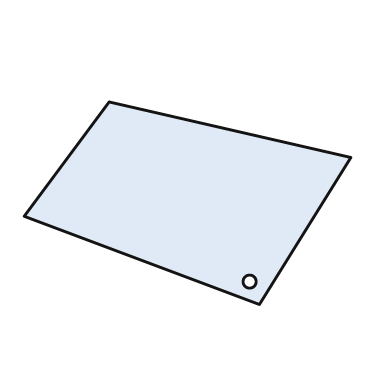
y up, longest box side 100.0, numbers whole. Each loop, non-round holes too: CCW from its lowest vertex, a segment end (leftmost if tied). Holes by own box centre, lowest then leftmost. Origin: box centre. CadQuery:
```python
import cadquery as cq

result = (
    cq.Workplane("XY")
    .moveTo(22.0, -31.0)
    .lineTo(50.0, 14.0)
    .lineTo(-24.0, 31.0)
    .lineTo(-50.0, -4.0)
    .close()
    .moveTo(19.0, -24.0)
    .circle(2.0)
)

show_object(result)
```